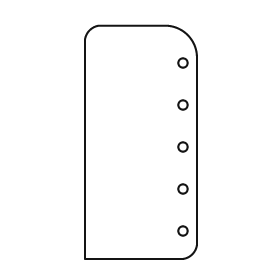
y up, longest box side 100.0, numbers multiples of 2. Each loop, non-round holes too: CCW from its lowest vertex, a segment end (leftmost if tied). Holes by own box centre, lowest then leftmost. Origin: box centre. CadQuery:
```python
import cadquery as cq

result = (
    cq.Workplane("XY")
    .moveTo(-24.0, -50.0)
    .lineTo(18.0, -50.0)
    .threePointArc((22.0, -48.0), (24.0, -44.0))
    .lineTo(24.0, 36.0)
    .threePointArc((20.0, 46.0), (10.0, 50.0))
    .lineTo(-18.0, 50.0)
    .threePointArc((-22.0, 48.0), (-24.0, 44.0))
    .close()
    .moveTo(18.0, -38.0)
    .circle(2.0)
    .moveTo(18.0, -20.0)
    .circle(2.0)
    .moveTo(18.0, -2.0)
    .circle(2.0)
    .moveTo(18.0, 16.0)
    .circle(2.0)
    .moveTo(18.0, 34.0)
    .circle(2.0)
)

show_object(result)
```